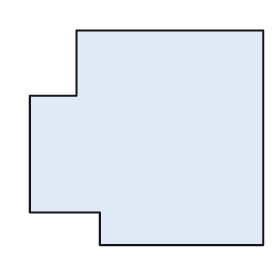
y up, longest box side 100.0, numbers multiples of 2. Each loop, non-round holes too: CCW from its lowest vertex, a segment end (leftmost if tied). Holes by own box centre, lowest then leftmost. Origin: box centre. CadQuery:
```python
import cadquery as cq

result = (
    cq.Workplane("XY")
    .moveTo(-20.0, -46.0)
    .lineTo(50.0, -46.0)
    .lineTo(50.0, 46.0)
    .lineTo(-30.0, 46.0)
    .lineTo(-30.0, 18.0)
    .lineTo(-50.0, 18.0)
    .lineTo(-50.0, -32.0)
    .lineTo(-20.0, -32.0)
    .close()
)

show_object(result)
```